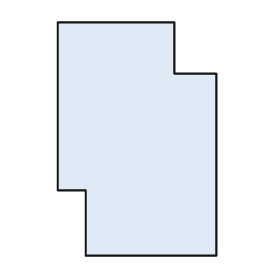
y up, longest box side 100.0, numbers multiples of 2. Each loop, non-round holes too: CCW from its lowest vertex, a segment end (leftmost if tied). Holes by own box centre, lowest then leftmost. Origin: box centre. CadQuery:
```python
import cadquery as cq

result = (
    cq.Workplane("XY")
    .moveTo(-22.0, -50.0)
    .lineTo(34.0, -50.0)
    .lineTo(34.0, 28.0)
    .lineTo(16.0, 28.0)
    .lineTo(16.0, 50.0)
    .lineTo(-34.0, 50.0)
    .lineTo(-34.0, -22.0)
    .lineTo(-22.0, -22.0)
    .close()
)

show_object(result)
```